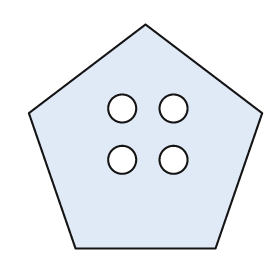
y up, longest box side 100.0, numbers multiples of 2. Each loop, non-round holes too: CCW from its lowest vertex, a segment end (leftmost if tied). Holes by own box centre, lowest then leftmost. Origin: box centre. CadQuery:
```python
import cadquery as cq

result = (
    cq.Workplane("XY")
    .moveTo(-30.0, -48.0)
    .lineTo(30.0, -48.0)
    .lineTo(50.0, 10.0)
    .lineTo(0.0, 48.0)
    .lineTo(-50.0, 10.0)
    .close()
    .moveTo(-10.0, -10.0)
    .circle(6.0)
    .moveTo(12.0, -10.0)
    .circle(6.0)
    .moveTo(-10.0, 12.0)
    .circle(6.0)
    .moveTo(12.0, 12.0)
    .circle(6.0)
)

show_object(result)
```